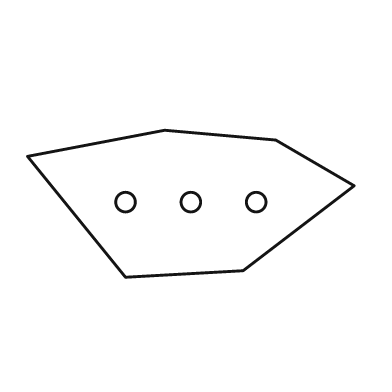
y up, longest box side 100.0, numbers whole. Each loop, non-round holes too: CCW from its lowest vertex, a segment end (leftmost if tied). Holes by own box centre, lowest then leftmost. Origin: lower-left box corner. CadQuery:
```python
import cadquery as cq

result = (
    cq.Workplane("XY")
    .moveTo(30.0, 0.0)
    .lineTo(66.0, 2.0)
    .lineTo(100.0, 28.0)
    .lineTo(76.0, 42.0)
    .lineTo(42.0, 45.0)
    .lineTo(0.0, 37.0)
    .close()
    .moveTo(30.0, 23.0)
    .circle(3.0)
    .moveTo(50.0, 23.0)
    .circle(3.0)
    .moveTo(70.0, 23.0)
    .circle(3.0)
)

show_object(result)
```